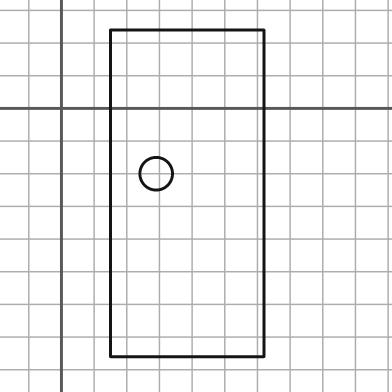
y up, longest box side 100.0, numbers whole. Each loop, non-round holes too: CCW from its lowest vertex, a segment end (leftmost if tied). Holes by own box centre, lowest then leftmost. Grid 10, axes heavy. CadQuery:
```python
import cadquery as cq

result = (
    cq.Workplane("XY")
    .moveTo(15.0, -76.0)
    .lineTo(62.0, -76.0)
    .lineTo(62.0, 24.0)
    .lineTo(15.0, 24.0)
    .close()
    .moveTo(29.0, -20.0)
    .circle(5.0)
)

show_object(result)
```